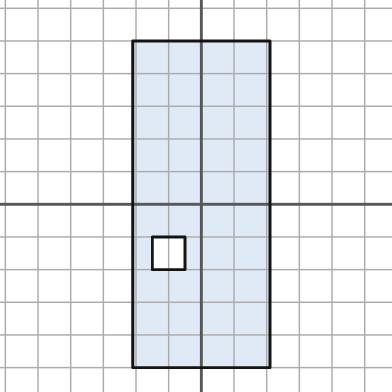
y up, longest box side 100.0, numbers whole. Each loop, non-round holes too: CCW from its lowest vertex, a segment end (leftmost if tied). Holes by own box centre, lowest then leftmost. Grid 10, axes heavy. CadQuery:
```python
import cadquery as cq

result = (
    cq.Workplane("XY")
    .moveTo(-21.0, -50.0)
    .lineTo(21.0, -50.0)
    .lineTo(21.0, 50.0)
    .lineTo(-21.0, 50.0)
    .close()
    .moveTo(-15.0, -20.0)
    .lineTo(-5.0, -20.0)
    .lineTo(-5.0, -10.0)
    .lineTo(-15.0, -10.0)
    .close()
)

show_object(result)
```